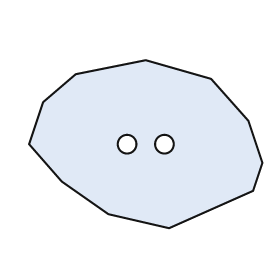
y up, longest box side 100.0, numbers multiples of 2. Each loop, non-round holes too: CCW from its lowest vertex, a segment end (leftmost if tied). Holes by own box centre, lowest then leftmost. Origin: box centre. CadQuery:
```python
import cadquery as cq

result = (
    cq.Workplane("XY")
    .moveTo(10.0, -36.0)
    .lineTo(46.0, -20.0)
    .lineTo(50.0, -8.0)
    .lineTo(44.0, 10.0)
    .lineTo(28.0, 28.0)
    .lineTo(0.0, 36.0)
    .lineTo(-30.0, 30.0)
    .lineTo(-44.0, 18.0)
    .lineTo(-50.0, 0.0)
    .lineTo(-36.0, -16.0)
    .lineTo(-16.0, -30.0)
    .close()
    .moveTo(-8.0, 0.0)
    .circle(4.0)
    .moveTo(8.0, 0.0)
    .circle(4.0)
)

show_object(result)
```